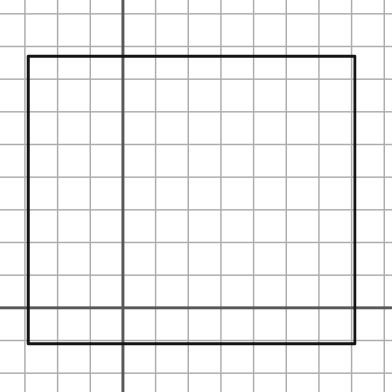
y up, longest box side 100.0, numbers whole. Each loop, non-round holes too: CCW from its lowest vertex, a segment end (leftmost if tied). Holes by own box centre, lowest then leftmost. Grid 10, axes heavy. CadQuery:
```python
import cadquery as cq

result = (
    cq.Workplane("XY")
    .moveTo(-29.0, -11.0)
    .lineTo(71.0, -11.0)
    .lineTo(71.0, 77.0)
    .lineTo(-29.0, 77.0)
    .close()
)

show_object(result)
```